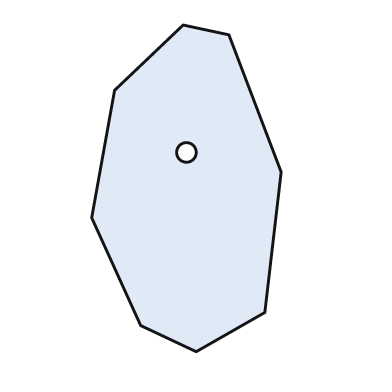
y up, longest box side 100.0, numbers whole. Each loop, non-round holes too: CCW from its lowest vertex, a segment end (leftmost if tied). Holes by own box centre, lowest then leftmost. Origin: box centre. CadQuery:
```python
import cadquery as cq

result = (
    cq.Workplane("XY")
    .moveTo(3.0, -50.0)
    .lineTo(24.0, -38.0)
    .lineTo(29.0, 5.0)
    .lineTo(13.0, 47.0)
    .lineTo(-1.0, 50.0)
    .lineTo(-22.0, 30.0)
    .lineTo(-29.0, -9.0)
    .lineTo(-14.0, -42.0)
    .close()
    .moveTo(0.0, 11.0)
    .circle(3.0)
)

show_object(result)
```